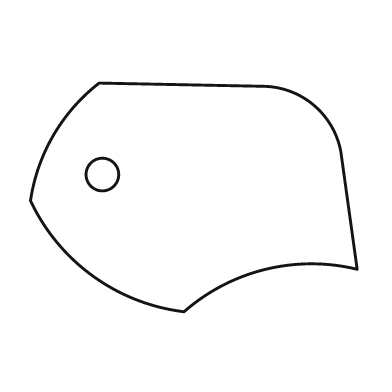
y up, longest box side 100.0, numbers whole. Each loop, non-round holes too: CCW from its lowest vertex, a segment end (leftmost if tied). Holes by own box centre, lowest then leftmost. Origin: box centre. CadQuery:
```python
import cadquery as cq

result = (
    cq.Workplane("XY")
    .moveTo(-3.0, -35.0)
    .threePointArc((22.0, -22.0), (50.0, -22.0))
    .lineTo(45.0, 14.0)
    .threePointArc((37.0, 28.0), (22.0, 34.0))
    .lineTo(-29.0, 35.0)
    .threePointArc((-43.0, 19.0), (-50.0, -1.0))
    .threePointArc((-31.0, -24.0), (-3.0, -35.0))
    .close()
    .moveTo(-28.0, 7.0)
    .circle(5.0)
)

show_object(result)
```